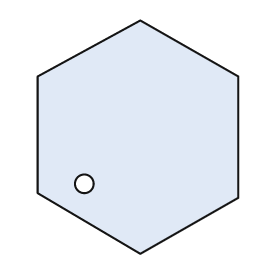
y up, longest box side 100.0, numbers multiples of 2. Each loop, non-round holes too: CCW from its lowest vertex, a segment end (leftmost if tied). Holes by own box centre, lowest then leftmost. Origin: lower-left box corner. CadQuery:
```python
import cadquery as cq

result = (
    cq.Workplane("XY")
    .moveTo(44.0, 0.0)
    .lineTo(86.0, 24.0)
    .lineTo(86.0, 76.0)
    .lineTo(44.0, 100.0)
    .lineTo(0.0, 76.0)
    .lineTo(0.0, 26.0)
    .close()
    .moveTo(20.0, 30.0)
    .circle(4.0)
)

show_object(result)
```